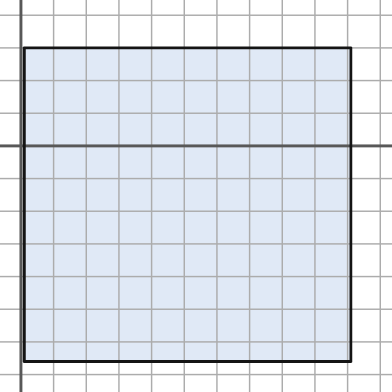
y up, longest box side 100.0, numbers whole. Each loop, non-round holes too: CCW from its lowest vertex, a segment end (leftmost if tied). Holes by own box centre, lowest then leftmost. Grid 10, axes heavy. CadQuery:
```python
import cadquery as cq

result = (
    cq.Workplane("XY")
    .moveTo(1.0, -66.0)
    .lineTo(101.0, -66.0)
    .lineTo(101.0, 30.0)
    .lineTo(1.0, 30.0)
    .close()
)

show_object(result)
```